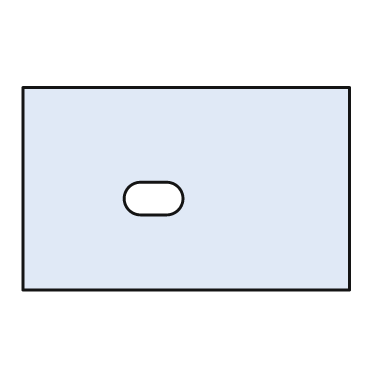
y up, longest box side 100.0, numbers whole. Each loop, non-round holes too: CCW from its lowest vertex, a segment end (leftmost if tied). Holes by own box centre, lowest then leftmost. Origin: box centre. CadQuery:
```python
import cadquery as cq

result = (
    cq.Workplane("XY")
    .moveTo(-50.0, -31.0)
    .lineTo(50.0, -31.0)
    .lineTo(50.0, 31.0)
    .lineTo(-50.0, 31.0)
    .close()
    .moveTo(-14.0, -8.0)
    .lineTo(-6.0, -8.0)
    .threePointArc((-1.0, -3.0), (-6.0, 2.0))
    .lineTo(-14.0, 2.0)
    .threePointArc((-19.0, -3.0), (-14.0, -8.0))
    .close()
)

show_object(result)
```